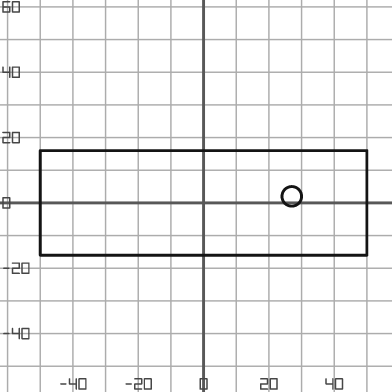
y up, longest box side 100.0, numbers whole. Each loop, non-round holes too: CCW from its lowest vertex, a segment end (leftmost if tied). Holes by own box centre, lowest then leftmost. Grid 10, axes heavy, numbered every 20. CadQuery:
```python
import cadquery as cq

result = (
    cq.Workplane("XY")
    .moveTo(-50.0, -16.0)
    .lineTo(50.0, -16.0)
    .lineTo(50.0, 16.0)
    .lineTo(-50.0, 16.0)
    .close()
    .moveTo(27.0, 2.0)
    .circle(3.0)
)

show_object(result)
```